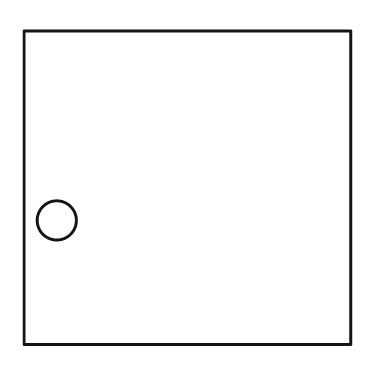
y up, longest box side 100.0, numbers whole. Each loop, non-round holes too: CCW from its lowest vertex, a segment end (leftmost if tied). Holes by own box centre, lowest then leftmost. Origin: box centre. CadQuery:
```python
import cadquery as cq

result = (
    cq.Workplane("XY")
    .moveTo(-50.0, -48.0)
    .lineTo(50.0, -48.0)
    .lineTo(50.0, 48.0)
    .lineTo(-50.0, 48.0)
    .close()
    .moveTo(-40.0, -10.0)
    .circle(6.0)
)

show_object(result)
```